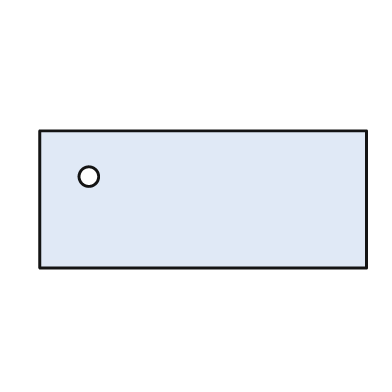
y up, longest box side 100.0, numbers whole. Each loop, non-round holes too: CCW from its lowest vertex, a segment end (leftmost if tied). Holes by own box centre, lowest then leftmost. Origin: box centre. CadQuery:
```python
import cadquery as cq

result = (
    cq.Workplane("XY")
    .moveTo(-50.0, -21.0)
    .lineTo(50.0, -21.0)
    .lineTo(50.0, 21.0)
    .lineTo(-50.0, 21.0)
    .close()
    .moveTo(-35.0, 7.0)
    .circle(3.0)
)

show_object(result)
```